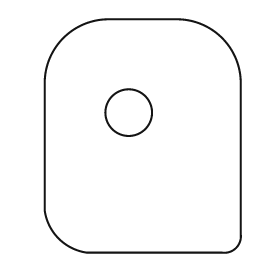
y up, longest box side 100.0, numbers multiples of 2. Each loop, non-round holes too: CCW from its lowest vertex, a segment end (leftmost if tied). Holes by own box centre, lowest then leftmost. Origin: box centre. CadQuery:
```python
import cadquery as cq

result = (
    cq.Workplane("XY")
    .moveTo(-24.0, -50.0)
    .lineTo(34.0, -50.0)
    .threePointArc((40.0, -48.0), (42.0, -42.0))
    .lineTo(42.0, 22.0)
    .threePointArc((34.0, 42.0), (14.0, 50.0))
    .lineTo(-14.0, 50.0)
    .threePointArc((-34.0, 42.0), (-42.0, 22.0))
    .lineTo(-42.0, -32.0)
    .threePointArc((-36.0, -44.0), (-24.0, -50.0))
    .close()
    .moveTo(-6.0, 10.0)
    .circle(10.0)
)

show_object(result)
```